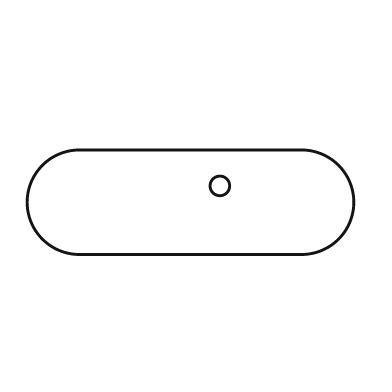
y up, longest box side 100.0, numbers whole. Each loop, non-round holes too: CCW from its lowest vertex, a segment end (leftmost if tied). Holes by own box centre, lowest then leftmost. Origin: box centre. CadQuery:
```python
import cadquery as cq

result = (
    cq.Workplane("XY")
    .moveTo(-34.0, -16.0)
    .lineTo(34.0, -16.0)
    .threePointArc((50.0, 0.0), (34.0, 16.0))
    .lineTo(-34.0, 16.0)
    .threePointArc((-50.0, 0.0), (-34.0, -16.0))
    .close()
    .moveTo(9.0, 5.0)
    .circle(3.0)
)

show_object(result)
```